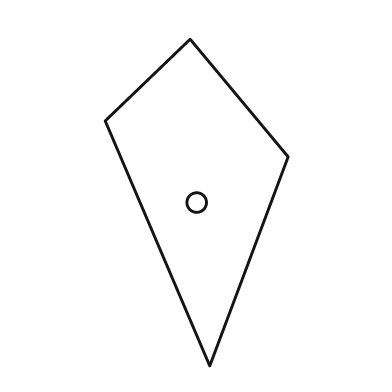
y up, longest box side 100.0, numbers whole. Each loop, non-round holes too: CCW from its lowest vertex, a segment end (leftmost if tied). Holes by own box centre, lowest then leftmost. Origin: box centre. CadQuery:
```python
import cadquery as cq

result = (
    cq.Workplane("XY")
    .moveTo(4.0, -50.0)
    .lineTo(28.0, 14.0)
    .lineTo(-2.0, 50.0)
    .lineTo(-28.0, 25.0)
    .close()
    .moveTo(0.0, 0.0)
    .circle(3.0)
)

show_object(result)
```